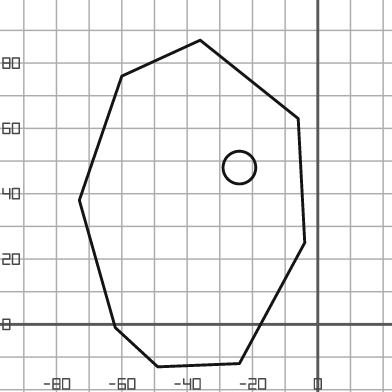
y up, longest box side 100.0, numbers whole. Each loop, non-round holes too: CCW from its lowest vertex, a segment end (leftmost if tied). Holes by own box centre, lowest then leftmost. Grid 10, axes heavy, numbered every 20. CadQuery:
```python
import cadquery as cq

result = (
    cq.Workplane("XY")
    .moveTo(-49.0, -13.0)
    .lineTo(-24.0, -12.0)
    .lineTo(-4.0, 25.0)
    .lineTo(-6.0, 63.0)
    .lineTo(-36.0, 87.0)
    .lineTo(-60.0, 76.0)
    .lineTo(-73.0, 38.0)
    .lineTo(-62.0, -1.0)
    .close()
    .moveTo(-24.0, 48.0)
    .circle(5.0)
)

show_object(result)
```